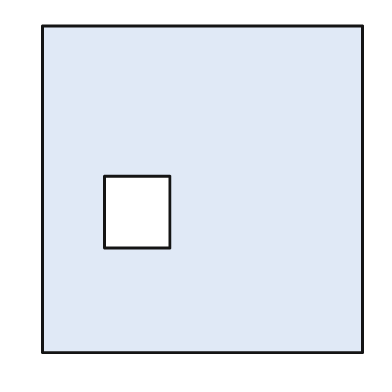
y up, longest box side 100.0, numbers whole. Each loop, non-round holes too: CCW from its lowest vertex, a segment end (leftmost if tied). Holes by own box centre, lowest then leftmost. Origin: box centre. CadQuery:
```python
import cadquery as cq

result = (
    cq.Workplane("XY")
    .moveTo(-49.0, -50.0)
    .lineTo(49.0, -50.0)
    .lineTo(49.0, 50.0)
    .lineTo(-49.0, 50.0)
    .close()
    .moveTo(-30.0, -18.0)
    .lineTo(-10.0, -18.0)
    .lineTo(-10.0, 4.0)
    .lineTo(-30.0, 4.0)
    .close()
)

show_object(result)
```